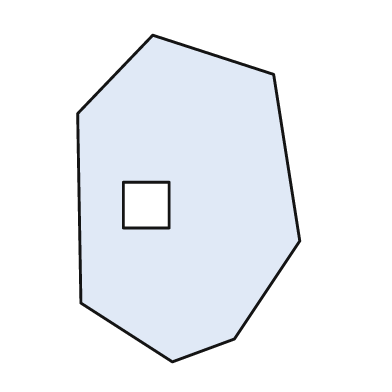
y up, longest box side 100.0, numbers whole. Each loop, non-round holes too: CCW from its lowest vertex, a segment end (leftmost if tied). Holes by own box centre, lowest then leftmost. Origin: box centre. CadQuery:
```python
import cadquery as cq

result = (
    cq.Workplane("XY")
    .moveTo(-5.0, -50.0)
    .lineTo(14.0, -43.0)
    .lineTo(34.0, -13.0)
    .lineTo(26.0, 38.0)
    .lineTo(-11.0, 50.0)
    .lineTo(-34.0, 26.0)
    .lineTo(-33.0, -32.0)
    .close()
    .moveTo(-20.0, -9.0)
    .lineTo(-6.0, -9.0)
    .lineTo(-6.0, 5.0)
    .lineTo(-20.0, 5.0)
    .close()
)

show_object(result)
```